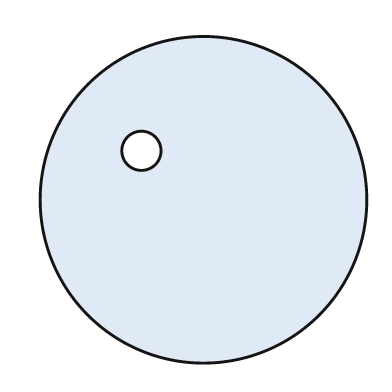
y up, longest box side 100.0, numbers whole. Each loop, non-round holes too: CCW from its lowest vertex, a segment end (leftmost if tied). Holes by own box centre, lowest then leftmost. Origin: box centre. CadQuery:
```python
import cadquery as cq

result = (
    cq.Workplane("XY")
    .moveTo(0.0, 0.0)
    .circle(50.0)
    .moveTo(-19.0, 15.0)
    .circle(6.0)
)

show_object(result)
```